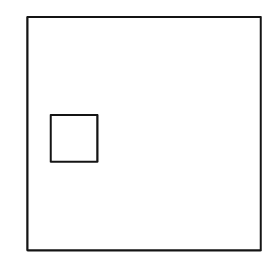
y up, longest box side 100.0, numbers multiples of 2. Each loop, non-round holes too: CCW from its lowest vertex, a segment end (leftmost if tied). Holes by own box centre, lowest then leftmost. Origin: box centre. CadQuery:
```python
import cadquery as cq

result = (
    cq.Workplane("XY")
    .moveTo(-50.0, -50.0)
    .lineTo(50.0, -50.0)
    .lineTo(50.0, 50.0)
    .lineTo(-50.0, 50.0)
    .close()
    .moveTo(-40.0, -12.0)
    .lineTo(-20.0, -12.0)
    .lineTo(-20.0, 8.0)
    .lineTo(-40.0, 8.0)
    .close()
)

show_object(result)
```